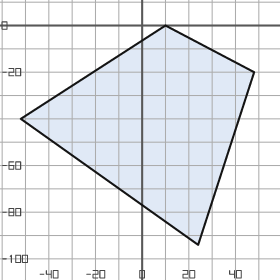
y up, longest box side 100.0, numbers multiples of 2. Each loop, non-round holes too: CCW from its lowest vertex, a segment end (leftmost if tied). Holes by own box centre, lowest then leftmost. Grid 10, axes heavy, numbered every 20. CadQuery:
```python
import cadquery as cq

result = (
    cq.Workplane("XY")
    .moveTo(24.0, -94.0)
    .lineTo(48.0, -20.0)
    .lineTo(10.0, 0.0)
    .lineTo(-52.0, -40.0)
    .close()
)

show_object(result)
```